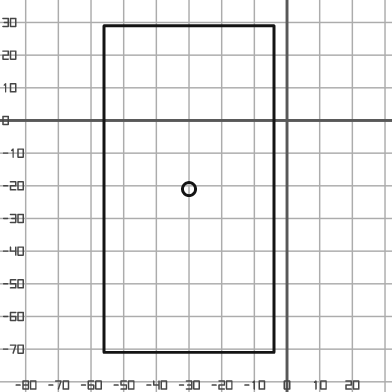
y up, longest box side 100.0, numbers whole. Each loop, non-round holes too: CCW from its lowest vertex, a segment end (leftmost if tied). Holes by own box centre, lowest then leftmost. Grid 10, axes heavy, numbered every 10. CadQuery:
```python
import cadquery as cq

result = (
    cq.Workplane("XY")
    .moveTo(-56.0, -71.0)
    .lineTo(-4.0, -71.0)
    .lineTo(-4.0, 29.0)
    .lineTo(-56.0, 29.0)
    .close()
    .moveTo(-30.0, -21.0)
    .circle(2.0)
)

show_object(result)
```